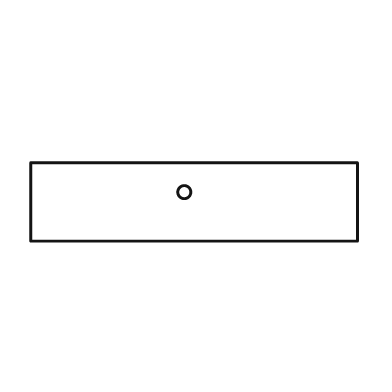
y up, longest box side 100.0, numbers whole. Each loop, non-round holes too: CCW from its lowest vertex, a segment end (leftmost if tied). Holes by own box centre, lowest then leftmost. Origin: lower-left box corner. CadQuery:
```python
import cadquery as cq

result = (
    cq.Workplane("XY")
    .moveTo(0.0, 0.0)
    .lineTo(100.0, 0.0)
    .lineTo(100.0, 24.0)
    .lineTo(0.0, 24.0)
    .close()
    .moveTo(47.0, 15.0)
    .circle(2.0)
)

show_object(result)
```